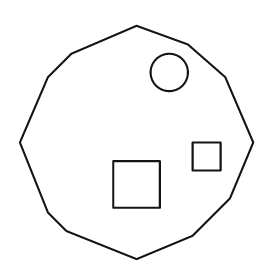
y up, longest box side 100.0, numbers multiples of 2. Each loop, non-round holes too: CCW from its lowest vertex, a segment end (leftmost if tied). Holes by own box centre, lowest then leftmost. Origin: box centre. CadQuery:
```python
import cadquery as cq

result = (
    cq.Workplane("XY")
    .moveTo(0.0, -50.0)
    .lineTo(24.0, -40.0)
    .lineTo(40.0, -24.0)
    .lineTo(50.0, 0.0)
    .lineTo(38.0, 28.0)
    .lineTo(22.0, 42.0)
    .lineTo(0.0, 50.0)
    .lineTo(-28.0, 38.0)
    .lineTo(-38.0, 28.0)
    .lineTo(-50.0, 0.0)
    .lineTo(-38.0, -30.0)
    .lineTo(-30.0, -38.0)
    .close()
    .moveTo(-10.0, -28.0)
    .lineTo(10.0, -28.0)
    .lineTo(10.0, -8.0)
    .lineTo(-10.0, -8.0)
    .close()
    .moveTo(24.0, -12.0)
    .lineTo(36.0, -12.0)
    .lineTo(36.0, 0.0)
    .lineTo(24.0, 0.0)
    .close()
    .moveTo(14.0, 30.0)
    .circle(8.0)
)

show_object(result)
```